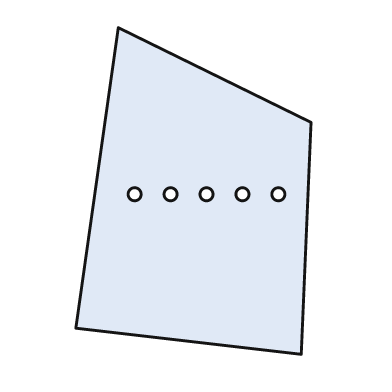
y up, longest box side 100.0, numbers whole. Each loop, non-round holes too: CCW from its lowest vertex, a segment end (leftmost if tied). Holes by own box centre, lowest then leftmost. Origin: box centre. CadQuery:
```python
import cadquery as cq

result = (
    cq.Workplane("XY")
    .moveTo(33.0, -50.0)
    .lineTo(36.0, 21.0)
    .lineTo(-23.0, 50.0)
    .lineTo(-36.0, -42.0)
    .close()
    .moveTo(-18.0, -1.0)
    .circle(2.0)
    .moveTo(-7.0, -1.0)
    .circle(2.0)
    .moveTo(4.0, -1.0)
    .circle(2.0)
    .moveTo(15.0, -1.0)
    .circle(2.0)
    .moveTo(26.0, -1.0)
    .circle(2.0)
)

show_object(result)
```